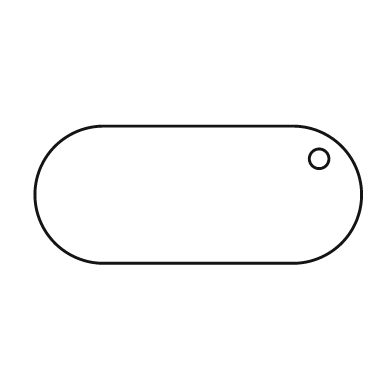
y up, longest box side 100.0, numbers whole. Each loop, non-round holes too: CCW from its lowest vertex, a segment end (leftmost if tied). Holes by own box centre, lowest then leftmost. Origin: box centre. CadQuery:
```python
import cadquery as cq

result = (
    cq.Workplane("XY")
    .moveTo(-29.0, -21.0)
    .lineTo(29.0, -21.0)
    .threePointArc((50.0, 0.0), (29.0, 21.0))
    .lineTo(-29.0, 21.0)
    .threePointArc((-50.0, 0.0), (-29.0, -21.0))
    .close()
    .moveTo(37.0, 11.0)
    .circle(3.0)
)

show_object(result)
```